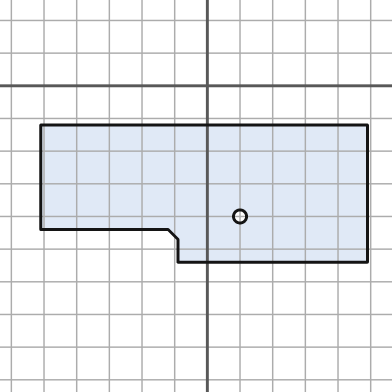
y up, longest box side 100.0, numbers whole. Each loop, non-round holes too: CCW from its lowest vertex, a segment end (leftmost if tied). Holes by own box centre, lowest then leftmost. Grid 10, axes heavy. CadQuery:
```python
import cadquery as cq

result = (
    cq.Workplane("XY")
    .moveTo(-9.0, -54.0)
    .lineTo(49.0, -54.0)
    .lineTo(49.0, -12.0)
    .lineTo(-51.0, -12.0)
    .lineTo(-51.0, -44.0)
    .lineTo(-12.0, -44.0)
    .lineTo(-9.0, -47.0)
    .close()
    .moveTo(10.0, -40.0)
    .circle(2.0)
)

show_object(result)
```